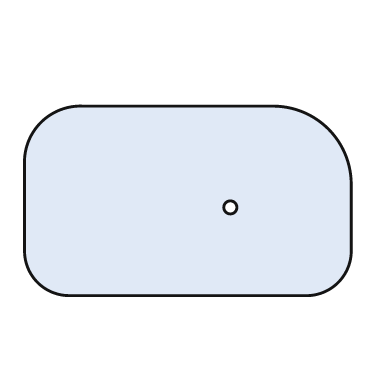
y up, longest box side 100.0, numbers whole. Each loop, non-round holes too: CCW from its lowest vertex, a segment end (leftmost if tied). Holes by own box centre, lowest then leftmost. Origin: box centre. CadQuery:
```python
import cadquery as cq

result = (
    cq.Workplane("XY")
    .moveTo(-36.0, -29.0)
    .lineTo(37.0, -29.0)
    .threePointArc((46.0, -25.0), (50.0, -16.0))
    .lineTo(50.0, 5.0)
    .threePointArc((43.0, 22.0), (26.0, 29.0))
    .lineTo(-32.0, 29.0)
    .threePointArc((-45.0, 24.0), (-50.0, 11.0))
    .lineTo(-50.0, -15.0)
    .threePointArc((-46.0, -25.0), (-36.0, -29.0))
    .close()
    .moveTo(13.0, -2.0)
    .circle(2.0)
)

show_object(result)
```